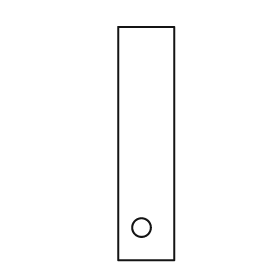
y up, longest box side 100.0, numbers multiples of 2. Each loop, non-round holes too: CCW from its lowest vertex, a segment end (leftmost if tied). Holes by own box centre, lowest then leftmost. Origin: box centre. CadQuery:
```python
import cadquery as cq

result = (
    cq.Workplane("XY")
    .moveTo(-12.0, -50.0)
    .lineTo(12.0, -50.0)
    .lineTo(12.0, 50.0)
    .lineTo(-12.0, 50.0)
    .close()
    .moveTo(-2.0, -36.0)
    .circle(4.0)
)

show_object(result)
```